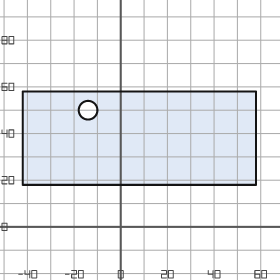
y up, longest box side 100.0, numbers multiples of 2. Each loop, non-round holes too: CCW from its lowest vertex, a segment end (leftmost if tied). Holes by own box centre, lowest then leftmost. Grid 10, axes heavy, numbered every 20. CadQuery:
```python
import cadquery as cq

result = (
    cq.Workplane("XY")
    .moveTo(-42.0, 18.0)
    .lineTo(58.0, 18.0)
    .lineTo(58.0, 58.0)
    .lineTo(-42.0, 58.0)
    .close()
    .moveTo(-14.0, 50.0)
    .circle(4.0)
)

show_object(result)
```